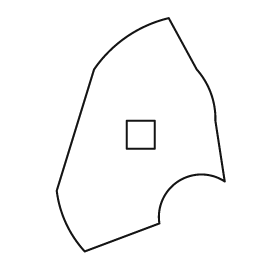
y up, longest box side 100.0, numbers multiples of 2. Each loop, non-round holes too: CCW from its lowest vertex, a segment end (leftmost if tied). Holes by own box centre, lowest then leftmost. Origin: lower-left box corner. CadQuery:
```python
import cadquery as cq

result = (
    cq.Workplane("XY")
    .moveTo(12.0, 0.0)
    .lineTo(44.0, 12.0)
    .threePointArc((52.0, 30.0), (72.0, 30.0))
    .lineTo(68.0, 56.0)
    .threePointArc((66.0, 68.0), (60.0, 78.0))
    .lineTo(48.0, 100.0)
    .threePointArc((30.0, 92.0), (16.0, 78.0))
    .lineTo(0.0, 26.0)
    .threePointArc((4.0, 12.0), (12.0, 0.0))
    .close()
    .moveTo(30.0, 44.0)
    .lineTo(42.0, 44.0)
    .lineTo(42.0, 56.0)
    .lineTo(30.0, 56.0)
    .close()
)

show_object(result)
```